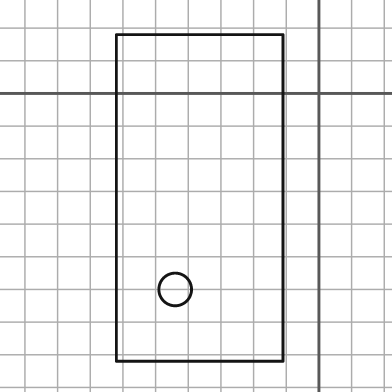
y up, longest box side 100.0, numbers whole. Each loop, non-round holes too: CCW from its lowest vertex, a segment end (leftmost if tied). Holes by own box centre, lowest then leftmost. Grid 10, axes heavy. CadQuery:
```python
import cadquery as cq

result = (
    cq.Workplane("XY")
    .moveTo(-62.0, -82.0)
    .lineTo(-11.0, -82.0)
    .lineTo(-11.0, 18.0)
    .lineTo(-62.0, 18.0)
    .close()
    .moveTo(-44.0, -60.0)
    .circle(5.0)
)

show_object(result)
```